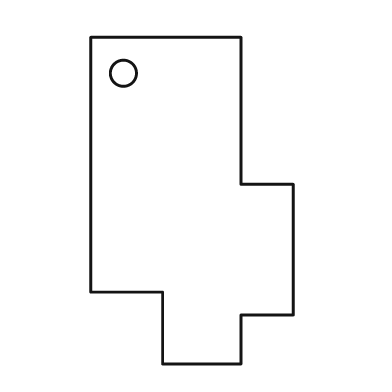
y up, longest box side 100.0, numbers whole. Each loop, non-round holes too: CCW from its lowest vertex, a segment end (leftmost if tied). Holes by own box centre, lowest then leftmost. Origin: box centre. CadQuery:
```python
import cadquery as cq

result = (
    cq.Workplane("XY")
    .moveTo(-9.0, -50.0)
    .lineTo(15.0, -50.0)
    .lineTo(15.0, -35.0)
    .lineTo(31.0, -35.0)
    .lineTo(31.0, 5.0)
    .lineTo(15.0, 5.0)
    .lineTo(15.0, 50.0)
    .lineTo(-31.0, 50.0)
    .lineTo(-31.0, -28.0)
    .lineTo(-9.0, -28.0)
    .close()
    .moveTo(-21.0, 39.0)
    .circle(4.0)
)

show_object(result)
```